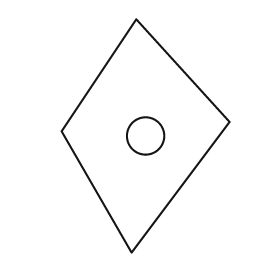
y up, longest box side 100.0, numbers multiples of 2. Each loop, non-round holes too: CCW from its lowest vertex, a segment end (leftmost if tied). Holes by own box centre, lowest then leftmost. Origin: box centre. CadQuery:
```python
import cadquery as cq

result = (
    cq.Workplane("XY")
    .moveTo(-6.0, -50.0)
    .lineTo(36.0, 6.0)
    .lineTo(-4.0, 50.0)
    .lineTo(-36.0, 2.0)
    .close()
    .moveTo(0.0, 0.0)
    .circle(8.0)
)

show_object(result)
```